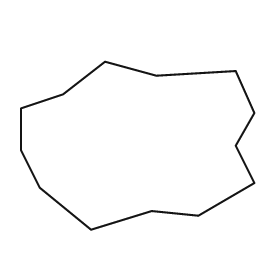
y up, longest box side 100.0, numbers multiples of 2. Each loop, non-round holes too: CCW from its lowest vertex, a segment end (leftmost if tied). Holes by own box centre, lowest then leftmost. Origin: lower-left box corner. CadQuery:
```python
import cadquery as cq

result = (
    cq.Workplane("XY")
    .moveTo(30.0, 0.0)
    .lineTo(56.0, 8.0)
    .lineTo(76.0, 6.0)
    .lineTo(100.0, 20.0)
    .lineTo(92.0, 36.0)
    .lineTo(100.0, 50.0)
    .lineTo(92.0, 68.0)
    .lineTo(58.0, 66.0)
    .lineTo(36.0, 72.0)
    .lineTo(18.0, 58.0)
    .lineTo(0.0, 52.0)
    .lineTo(0.0, 34.0)
    .lineTo(8.0, 18.0)
    .close()
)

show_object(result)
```